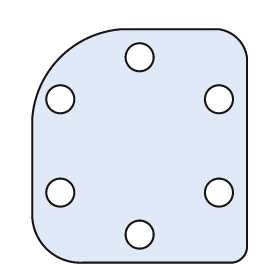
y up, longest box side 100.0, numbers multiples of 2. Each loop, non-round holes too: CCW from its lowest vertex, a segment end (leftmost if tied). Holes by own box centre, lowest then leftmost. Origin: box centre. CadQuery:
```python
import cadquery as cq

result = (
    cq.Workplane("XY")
    .moveTo(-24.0, -50.0)
    .lineTo(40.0, -50.0)
    .threePointArc((44.0, -48.0), (46.0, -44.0))
    .lineTo(46.0, 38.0)
    .threePointArc((42.0, 46.0), (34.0, 50.0))
    .lineTo(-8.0, 50.0)
    .threePointArc((-34.0, 38.0), (-46.0, 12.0))
    .lineTo(-46.0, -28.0)
    .threePointArc((-40.0, -44.0), (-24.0, -50.0))
    .close()
    .moveTo(0.0, -38.0)
    .circle(6.0)
    .moveTo(-34.0, -20.0)
    .circle(6.0)
    .moveTo(34.0, -20.0)
    .circle(6.0)
    .moveTo(-34.0, 20.0)
    .circle(6.0)
    .moveTo(34.0, 20.0)
    .circle(6.0)
    .moveTo(0.0, 38.0)
    .circle(6.0)
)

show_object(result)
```